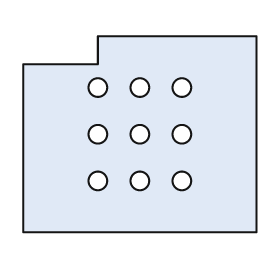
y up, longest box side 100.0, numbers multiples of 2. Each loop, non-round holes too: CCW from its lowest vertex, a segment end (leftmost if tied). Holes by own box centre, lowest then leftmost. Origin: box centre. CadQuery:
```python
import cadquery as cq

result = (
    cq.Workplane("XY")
    .moveTo(-50.0, -42.0)
    .lineTo(50.0, -42.0)
    .lineTo(50.0, 42.0)
    .lineTo(-18.0, 42.0)
    .lineTo(-18.0, 30.0)
    .lineTo(-50.0, 30.0)
    .close()
    .moveTo(-18.0, -20.0)
    .circle(4.0)
    .moveTo(0.0, -20.0)
    .circle(4.0)
    .moveTo(18.0, -20.0)
    .circle(4.0)
    .moveTo(-18.0, 0.0)
    .circle(4.0)
    .moveTo(0.0, 0.0)
    .circle(4.0)
    .moveTo(18.0, 0.0)
    .circle(4.0)
    .moveTo(-18.0, 20.0)
    .circle(4.0)
    .moveTo(0.0, 20.0)
    .circle(4.0)
    .moveTo(18.0, 20.0)
    .circle(4.0)
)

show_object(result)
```